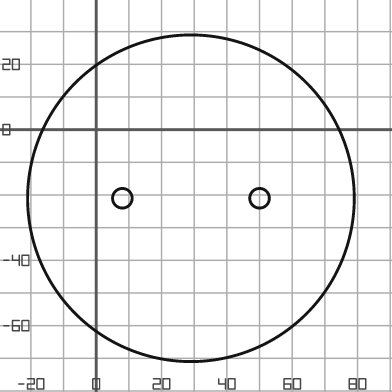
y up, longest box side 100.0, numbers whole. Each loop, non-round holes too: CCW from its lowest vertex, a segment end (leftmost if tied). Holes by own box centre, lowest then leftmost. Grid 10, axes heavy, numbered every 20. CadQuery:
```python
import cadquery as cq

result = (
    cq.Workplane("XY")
    .moveTo(29.0, -21.0)
    .circle(50.0)
    .moveTo(8.0, -21.0)
    .circle(3.0)
    .moveTo(50.0, -21.0)
    .circle(3.0)
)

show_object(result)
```